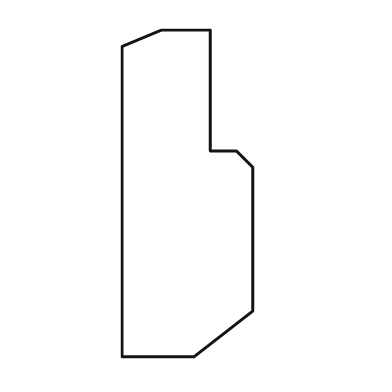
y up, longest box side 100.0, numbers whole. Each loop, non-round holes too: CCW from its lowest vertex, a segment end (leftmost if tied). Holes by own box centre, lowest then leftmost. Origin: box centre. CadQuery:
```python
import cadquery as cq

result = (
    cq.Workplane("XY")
    .moveTo(-20.0, -50.0)
    .lineTo(2.0, -50.0)
    .lineTo(20.0, -36.0)
    .lineTo(20.0, 8.0)
    .lineTo(15.0, 13.0)
    .lineTo(7.0, 13.0)
    .lineTo(7.0, 50.0)
    .lineTo(-8.0, 50.0)
    .lineTo(-20.0, 45.0)
    .close()
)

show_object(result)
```